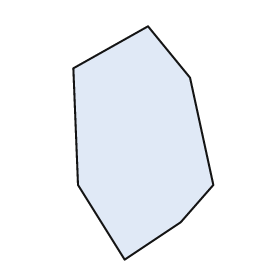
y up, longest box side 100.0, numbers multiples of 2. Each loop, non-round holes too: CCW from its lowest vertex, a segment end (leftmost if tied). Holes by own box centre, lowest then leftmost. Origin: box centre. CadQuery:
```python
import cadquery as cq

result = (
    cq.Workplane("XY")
    .moveTo(-8.0, -50.0)
    .lineTo(16.0, -34.0)
    .lineTo(30.0, -18.0)
    .lineTo(20.0, 28.0)
    .lineTo(2.0, 50.0)
    .lineTo(-30.0, 32.0)
    .lineTo(-28.0, -18.0)
    .close()
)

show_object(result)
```